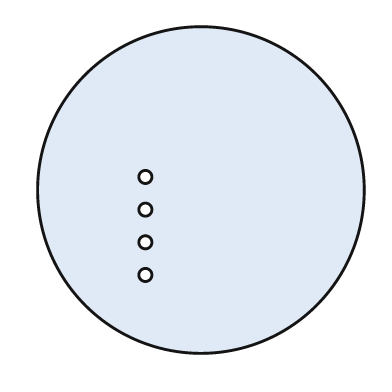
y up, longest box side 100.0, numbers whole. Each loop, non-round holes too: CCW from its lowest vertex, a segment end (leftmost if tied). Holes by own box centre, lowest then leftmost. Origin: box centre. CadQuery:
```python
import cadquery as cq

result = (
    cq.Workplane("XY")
    .moveTo(0.0, 0.0)
    .circle(50.0)
    .moveTo(-17.0, -26.0)
    .circle(2.0)
    .moveTo(-17.0, -16.0)
    .circle(2.0)
    .moveTo(-17.0, -6.0)
    .circle(2.0)
    .moveTo(-17.0, 4.0)
    .circle(2.0)
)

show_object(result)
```